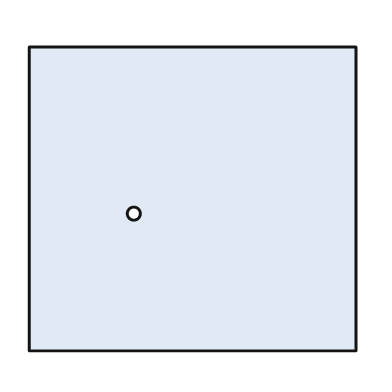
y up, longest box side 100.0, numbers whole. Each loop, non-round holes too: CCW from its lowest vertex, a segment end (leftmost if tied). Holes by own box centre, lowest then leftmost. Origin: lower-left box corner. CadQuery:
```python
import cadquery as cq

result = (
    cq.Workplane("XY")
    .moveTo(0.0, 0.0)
    .lineTo(100.0, 0.0)
    .lineTo(100.0, 93.0)
    .lineTo(0.0, 93.0)
    .close()
    .moveTo(32.0, 42.0)
    .circle(2.0)
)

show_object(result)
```